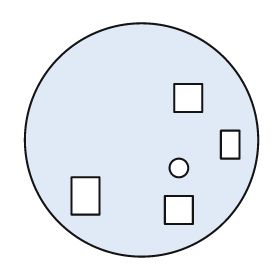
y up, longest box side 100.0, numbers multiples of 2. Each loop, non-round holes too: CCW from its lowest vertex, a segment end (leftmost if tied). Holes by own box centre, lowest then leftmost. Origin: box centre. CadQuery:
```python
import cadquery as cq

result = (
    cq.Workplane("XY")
    .moveTo(0.0, 0.0)
    .circle(50.0)
    .moveTo(10.0, -36.0)
    .lineTo(22.0, -36.0)
    .lineTo(22.0, -24.0)
    .lineTo(10.0, -24.0)
    .close()
    .moveTo(-30.0, -32.0)
    .lineTo(-18.0, -32.0)
    .lineTo(-18.0, -16.0)
    .lineTo(-30.0, -16.0)
    .close()
    .moveTo(16.0, -12.0)
    .circle(4.0)
    .moveTo(34.0, -8.0)
    .lineTo(42.0, -8.0)
    .lineTo(42.0, 4.0)
    .lineTo(34.0, 4.0)
    .close()
    .moveTo(14.0, 12.0)
    .lineTo(26.0, 12.0)
    .lineTo(26.0, 24.0)
    .lineTo(14.0, 24.0)
    .close()
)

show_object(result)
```